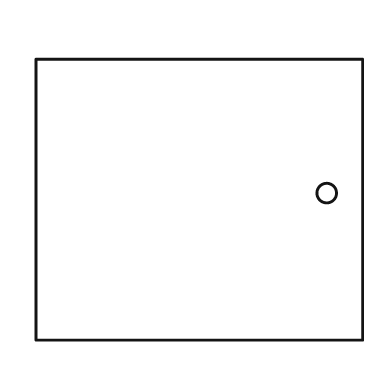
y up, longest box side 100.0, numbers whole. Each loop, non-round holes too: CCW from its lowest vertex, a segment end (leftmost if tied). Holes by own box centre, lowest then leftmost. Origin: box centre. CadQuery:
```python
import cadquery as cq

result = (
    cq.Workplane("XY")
    .moveTo(-50.0, -43.0)
    .lineTo(50.0, -43.0)
    .lineTo(50.0, 43.0)
    .lineTo(-50.0, 43.0)
    .close()
    .moveTo(39.0, 2.0)
    .circle(3.0)
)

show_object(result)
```